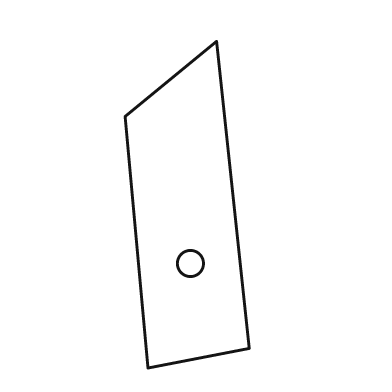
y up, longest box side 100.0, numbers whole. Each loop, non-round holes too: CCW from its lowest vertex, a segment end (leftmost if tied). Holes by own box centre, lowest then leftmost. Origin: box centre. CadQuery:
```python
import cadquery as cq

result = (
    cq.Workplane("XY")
    .moveTo(-12.0, -50.0)
    .lineTo(19.0, -44.0)
    .lineTo(9.0, 50.0)
    .lineTo(-19.0, 27.0)
    .close()
    .moveTo(1.0, -18.0)
    .circle(4.0)
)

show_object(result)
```